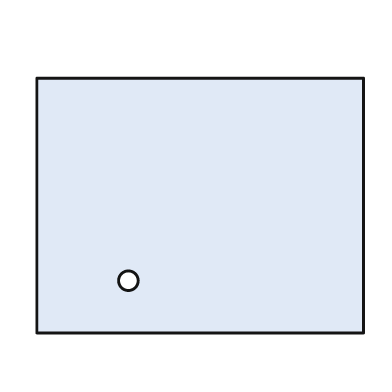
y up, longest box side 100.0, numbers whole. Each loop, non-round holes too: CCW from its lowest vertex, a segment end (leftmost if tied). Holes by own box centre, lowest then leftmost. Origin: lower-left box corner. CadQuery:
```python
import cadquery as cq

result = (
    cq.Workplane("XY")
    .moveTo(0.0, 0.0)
    .lineTo(100.0, 0.0)
    .lineTo(100.0, 78.0)
    .lineTo(0.0, 78.0)
    .close()
    .moveTo(28.0, 16.0)
    .circle(3.0)
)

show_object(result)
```